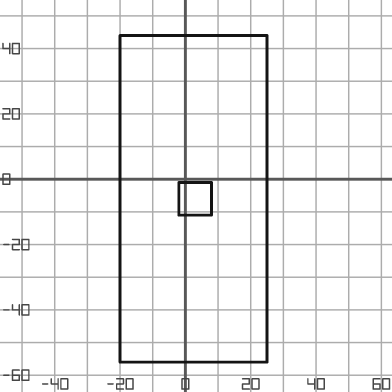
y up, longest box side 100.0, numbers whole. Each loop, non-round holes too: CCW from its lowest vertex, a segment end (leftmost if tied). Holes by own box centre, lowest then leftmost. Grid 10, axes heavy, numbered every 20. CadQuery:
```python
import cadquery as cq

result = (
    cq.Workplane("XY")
    .moveTo(-20.0, -56.0)
    .lineTo(25.0, -56.0)
    .lineTo(25.0, 44.0)
    .lineTo(-20.0, 44.0)
    .close()
    .moveTo(-2.0, -11.0)
    .lineTo(8.0, -11.0)
    .lineTo(8.0, -1.0)
    .lineTo(-2.0, -1.0)
    .close()
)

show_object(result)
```